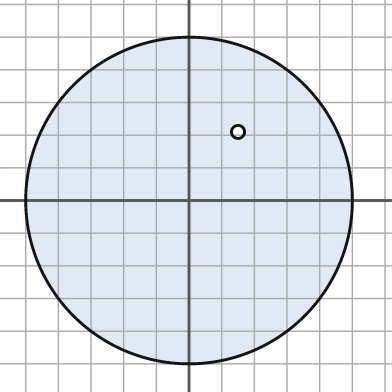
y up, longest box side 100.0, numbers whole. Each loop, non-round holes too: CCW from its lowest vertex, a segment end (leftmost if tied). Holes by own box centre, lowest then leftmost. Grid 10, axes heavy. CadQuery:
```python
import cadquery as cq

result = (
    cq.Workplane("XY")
    .moveTo(0.0, 0.0)
    .circle(50.0)
    .moveTo(15.0, 21.0)
    .circle(2.0)
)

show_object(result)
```